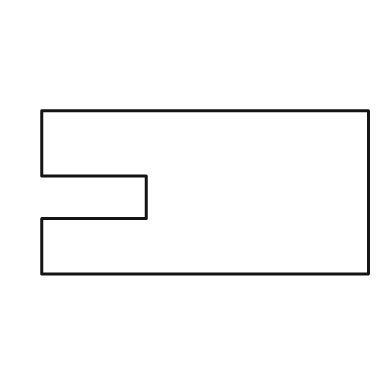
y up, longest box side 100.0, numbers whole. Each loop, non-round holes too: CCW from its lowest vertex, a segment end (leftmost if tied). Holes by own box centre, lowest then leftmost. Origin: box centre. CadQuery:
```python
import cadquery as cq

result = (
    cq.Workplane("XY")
    .moveTo(-50.0, -25.0)
    .lineTo(50.0, -25.0)
    .lineTo(50.0, 25.0)
    .lineTo(-50.0, 25.0)
    .lineTo(-50.0, 5.0)
    .lineTo(-18.0, 5.0)
    .lineTo(-18.0, -8.0)
    .lineTo(-50.0, -8.0)
    .close()
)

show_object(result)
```